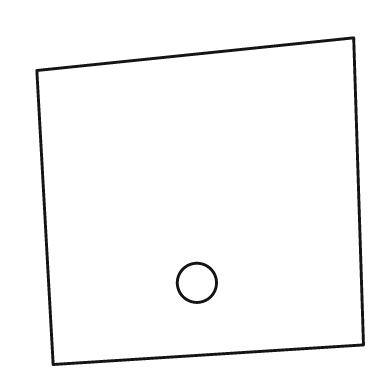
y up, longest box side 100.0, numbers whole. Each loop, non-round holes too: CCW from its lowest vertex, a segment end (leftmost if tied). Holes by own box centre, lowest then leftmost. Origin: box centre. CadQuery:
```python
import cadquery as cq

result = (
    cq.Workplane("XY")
    .moveTo(-45.0, -50.0)
    .lineTo(50.0, -44.0)
    .lineTo(47.0, 50.0)
    .lineTo(-50.0, 40.0)
    .close()
    .moveTo(-1.0, -25.0)
    .circle(6.0)
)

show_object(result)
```